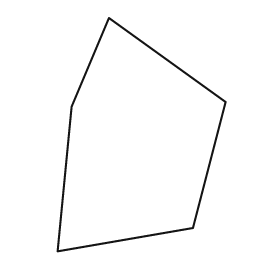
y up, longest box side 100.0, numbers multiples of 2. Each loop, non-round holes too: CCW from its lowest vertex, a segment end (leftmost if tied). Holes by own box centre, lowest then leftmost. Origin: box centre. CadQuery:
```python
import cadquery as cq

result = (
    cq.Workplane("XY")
    .moveTo(-36.0, -50.0)
    .lineTo(22.0, -40.0)
    .lineTo(36.0, 14.0)
    .lineTo(-14.0, 50.0)
    .lineTo(-30.0, 12.0)
    .close()
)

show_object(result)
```